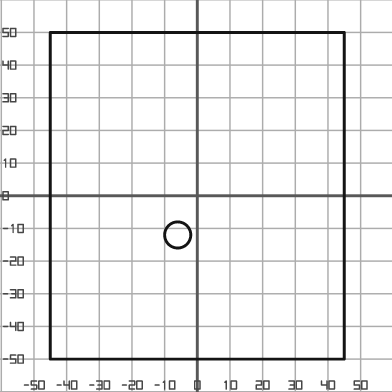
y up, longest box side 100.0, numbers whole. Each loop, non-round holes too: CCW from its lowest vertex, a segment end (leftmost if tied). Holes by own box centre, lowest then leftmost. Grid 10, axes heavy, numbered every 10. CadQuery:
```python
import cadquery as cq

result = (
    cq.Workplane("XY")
    .moveTo(-45.0, -50.0)
    .lineTo(45.0, -50.0)
    .lineTo(45.0, 50.0)
    .lineTo(-45.0, 50.0)
    .close()
    .moveTo(-6.0, -12.0)
    .circle(4.0)
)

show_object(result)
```